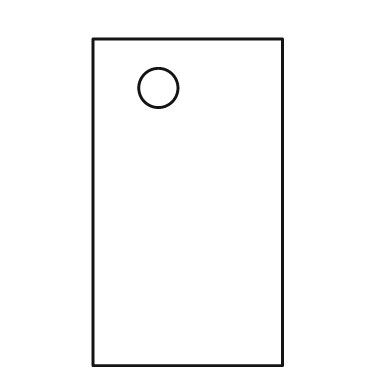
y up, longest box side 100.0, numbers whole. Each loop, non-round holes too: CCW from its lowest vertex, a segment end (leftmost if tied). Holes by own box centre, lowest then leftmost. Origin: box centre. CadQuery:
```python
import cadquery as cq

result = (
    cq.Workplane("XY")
    .moveTo(-29.0, -50.0)
    .lineTo(29.0, -50.0)
    .lineTo(29.0, 50.0)
    .lineTo(-29.0, 50.0)
    .close()
    .moveTo(-9.0, 35.0)
    .circle(6.0)
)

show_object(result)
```